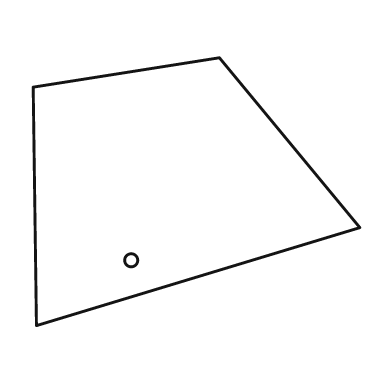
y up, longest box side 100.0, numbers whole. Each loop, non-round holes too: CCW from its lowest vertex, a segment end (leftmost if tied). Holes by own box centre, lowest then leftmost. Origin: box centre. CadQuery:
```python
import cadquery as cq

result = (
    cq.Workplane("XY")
    .moveTo(-49.0, -41.0)
    .lineTo(50.0, -11.0)
    .lineTo(7.0, 41.0)
    .lineTo(-50.0, 32.0)
    .close()
    .moveTo(-20.0, -21.0)
    .circle(2.0)
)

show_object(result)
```